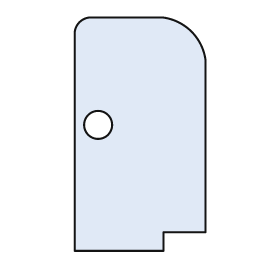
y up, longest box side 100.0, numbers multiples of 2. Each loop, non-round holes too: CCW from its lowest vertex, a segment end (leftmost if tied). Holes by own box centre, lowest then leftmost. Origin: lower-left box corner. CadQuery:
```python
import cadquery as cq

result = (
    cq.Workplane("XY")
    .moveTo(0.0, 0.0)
    .lineTo(38.0, 0.0)
    .lineTo(38.0, 8.0)
    .lineTo(56.0, 8.0)
    .lineTo(56.0, 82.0)
    .threePointArc((50.0, 94.0), (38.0, 100.0))
    .lineTo(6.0, 100.0)
    .threePointArc((2.0, 98.0), (0.0, 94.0))
    .close()
    .moveTo(10.0, 54.0)
    .circle(6.0)
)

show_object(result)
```